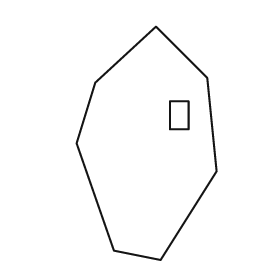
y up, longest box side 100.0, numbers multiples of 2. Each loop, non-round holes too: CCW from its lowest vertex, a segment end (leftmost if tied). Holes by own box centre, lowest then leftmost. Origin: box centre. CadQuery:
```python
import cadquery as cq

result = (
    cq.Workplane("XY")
    .moveTo(6.0, -50.0)
    .lineTo(30.0, -12.0)
    .lineTo(26.0, 28.0)
    .lineTo(4.0, 50.0)
    .lineTo(-22.0, 26.0)
    .lineTo(-30.0, 0.0)
    .lineTo(-14.0, -46.0)
    .close()
    .moveTo(10.0, 6.0)
    .lineTo(18.0, 6.0)
    .lineTo(18.0, 18.0)
    .lineTo(10.0, 18.0)
    .close()
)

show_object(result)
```